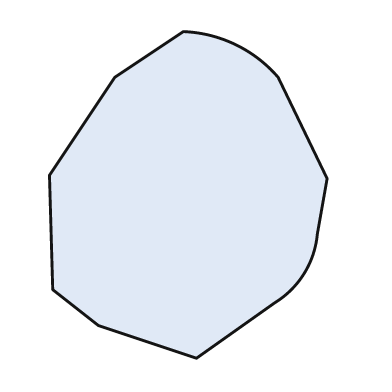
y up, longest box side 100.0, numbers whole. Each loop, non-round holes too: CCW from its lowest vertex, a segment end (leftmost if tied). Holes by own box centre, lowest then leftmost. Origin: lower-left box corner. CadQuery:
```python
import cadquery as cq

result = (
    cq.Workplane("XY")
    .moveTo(45.0, 0.0)
    .lineTo(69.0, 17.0)
    .threePointArc((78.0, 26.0), (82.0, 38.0))
    .lineTo(85.0, 55.0)
    .lineTo(70.0, 86.0)
    .threePointArc((57.0, 96.0), (41.0, 100.0))
    .lineTo(20.0, 86.0)
    .lineTo(0.0, 56.0)
    .lineTo(1.0, 21.0)
    .lineTo(15.0, 10.0)
    .close()
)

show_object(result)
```